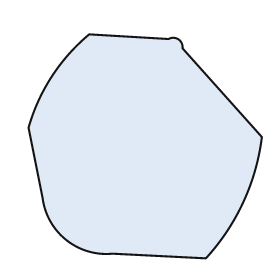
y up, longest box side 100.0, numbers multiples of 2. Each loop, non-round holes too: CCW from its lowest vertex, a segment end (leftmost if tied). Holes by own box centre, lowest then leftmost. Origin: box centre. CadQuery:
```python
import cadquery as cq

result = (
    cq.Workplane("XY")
    .moveTo(26.0, -48.0)
    .threePointArc((42.0, -24.0), (50.0, 4.0))
    .lineTo(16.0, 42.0)
    .threePointArc((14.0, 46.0), (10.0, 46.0))
    .lineTo(-24.0, 48.0)
    .threePointArc((-40.0, 30.0), (-50.0, 8.0))
    .lineTo(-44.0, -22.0)
    .threePointArc((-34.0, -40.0), (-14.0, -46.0))
    .close()
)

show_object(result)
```